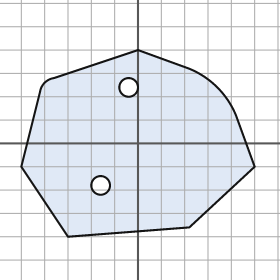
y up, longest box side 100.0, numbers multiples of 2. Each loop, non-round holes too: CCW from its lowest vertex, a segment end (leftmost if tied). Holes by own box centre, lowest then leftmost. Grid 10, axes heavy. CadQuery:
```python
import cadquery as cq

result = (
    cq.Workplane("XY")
    .moveTo(-30.0, -40.0)
    .lineTo(22.0, -36.0)
    .lineTo(50.0, -10.0)
    .lineTo(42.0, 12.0)
    .threePointArc((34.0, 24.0), (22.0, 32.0))
    .lineTo(0.0, 40.0)
    .lineTo(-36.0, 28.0)
    .threePointArc((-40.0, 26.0), (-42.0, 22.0))
    .lineTo(-50.0, -10.0)
    .close()
    .moveTo(-16.0, -18.0)
    .circle(4.0)
    .moveTo(-4.0, 24.0)
    .circle(4.0)
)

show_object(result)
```